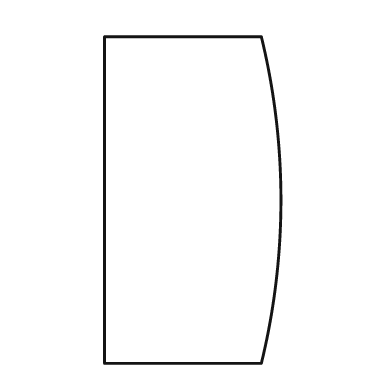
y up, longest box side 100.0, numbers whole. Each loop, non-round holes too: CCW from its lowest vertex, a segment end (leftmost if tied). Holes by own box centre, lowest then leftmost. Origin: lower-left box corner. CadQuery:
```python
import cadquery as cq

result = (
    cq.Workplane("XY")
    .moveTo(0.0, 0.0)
    .lineTo(48.0, 0.0)
    .threePointArc((54.0, 50.0), (48.0, 100.0))
    .lineTo(0.0, 100.0)
    .close()
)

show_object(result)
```